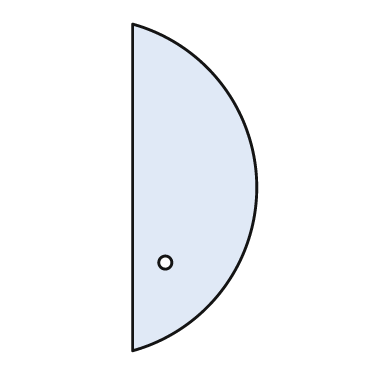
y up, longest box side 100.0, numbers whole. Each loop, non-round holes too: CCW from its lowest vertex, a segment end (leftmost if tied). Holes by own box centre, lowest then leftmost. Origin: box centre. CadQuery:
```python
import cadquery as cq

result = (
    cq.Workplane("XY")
    .moveTo(-19.0, -50.0)
    .threePointArc((19.0, 0.0), (-19.0, 50.0))
    .close()
    .moveTo(-9.0, -23.0)
    .circle(2.0)
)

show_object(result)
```